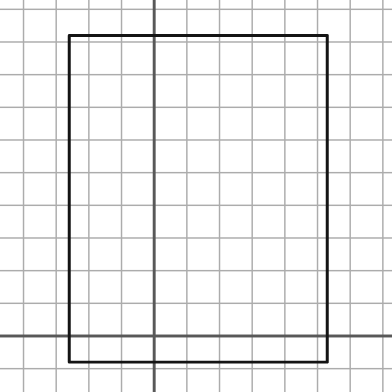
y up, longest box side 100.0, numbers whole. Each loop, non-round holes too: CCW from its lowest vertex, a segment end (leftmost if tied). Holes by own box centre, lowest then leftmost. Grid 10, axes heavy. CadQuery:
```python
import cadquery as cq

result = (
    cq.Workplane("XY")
    .moveTo(-26.0, -8.0)
    .lineTo(53.0, -8.0)
    .lineTo(53.0, 92.0)
    .lineTo(-26.0, 92.0)
    .close()
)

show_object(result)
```